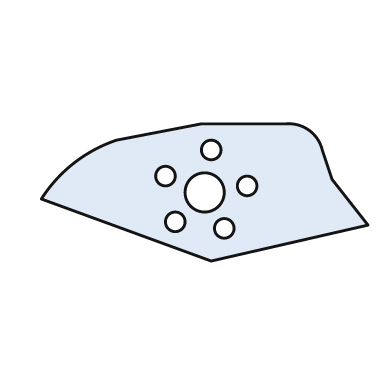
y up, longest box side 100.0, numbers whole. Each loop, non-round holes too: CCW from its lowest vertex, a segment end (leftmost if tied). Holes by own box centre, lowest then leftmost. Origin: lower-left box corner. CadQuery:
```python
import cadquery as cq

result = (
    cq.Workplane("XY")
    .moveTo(52.0, 0.0)
    .lineTo(100.0, 11.0)
    .lineTo(89.0, 25.0)
    .lineTo(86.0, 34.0)
    .threePointArc((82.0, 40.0), (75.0, 42.0))
    .lineTo(49.0, 42.0)
    .lineTo(23.0, 37.0)
    .threePointArc((10.0, 30.0), (0.0, 19.0))
    .close()
    .moveTo(56.0, 10.0)
    .circle(3.0)
    .moveTo(41.0, 12.0)
    .circle(3.0)
    .moveTo(50.0, 21.0)
    .circle(6.0)
    .moveTo(63.0, 23.0)
    .circle(3.0)
    .moveTo(38.0, 26.0)
    .circle(3.0)
    .moveTo(52.0, 34.0)
    .circle(3.0)
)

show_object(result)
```